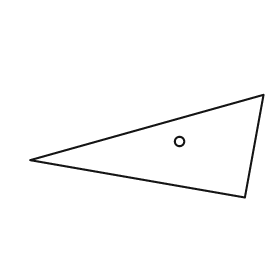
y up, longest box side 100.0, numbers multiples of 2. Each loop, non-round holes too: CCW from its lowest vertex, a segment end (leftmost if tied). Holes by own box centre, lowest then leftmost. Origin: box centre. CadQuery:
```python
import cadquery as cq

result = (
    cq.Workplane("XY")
    .moveTo(42.0, -22.0)
    .lineTo(50.0, 22.0)
    .lineTo(-50.0, -6.0)
    .close()
    .moveTo(14.0, 2.0)
    .circle(2.0)
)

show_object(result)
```